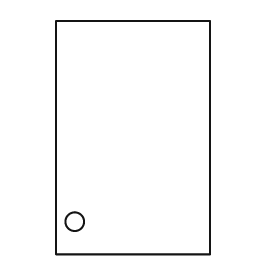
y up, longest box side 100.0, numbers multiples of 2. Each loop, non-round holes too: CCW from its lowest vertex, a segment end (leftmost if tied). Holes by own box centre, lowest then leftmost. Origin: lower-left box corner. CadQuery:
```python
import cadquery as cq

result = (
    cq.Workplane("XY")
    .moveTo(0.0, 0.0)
    .lineTo(66.0, 0.0)
    .lineTo(66.0, 100.0)
    .lineTo(0.0, 100.0)
    .close()
    .moveTo(8.0, 14.0)
    .circle(4.0)
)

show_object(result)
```